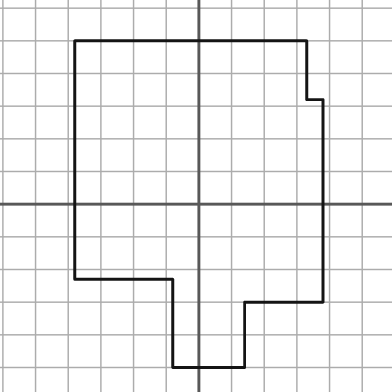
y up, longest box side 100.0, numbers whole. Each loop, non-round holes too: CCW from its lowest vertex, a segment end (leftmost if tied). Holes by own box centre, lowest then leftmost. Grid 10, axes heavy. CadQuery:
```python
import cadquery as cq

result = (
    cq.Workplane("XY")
    .moveTo(-8.0, -50.0)
    .lineTo(14.0, -50.0)
    .lineTo(14.0, -30.0)
    .lineTo(38.0, -30.0)
    .lineTo(38.0, 32.0)
    .lineTo(33.0, 32.0)
    .lineTo(33.0, 50.0)
    .lineTo(-38.0, 50.0)
    .lineTo(-38.0, -23.0)
    .lineTo(-8.0, -23.0)
    .close()
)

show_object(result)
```